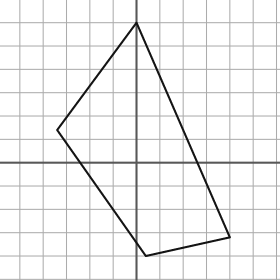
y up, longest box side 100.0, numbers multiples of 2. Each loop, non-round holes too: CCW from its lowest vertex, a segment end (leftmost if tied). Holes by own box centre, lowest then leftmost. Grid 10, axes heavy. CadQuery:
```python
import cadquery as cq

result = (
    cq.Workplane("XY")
    .moveTo(4.0, -40.0)
    .lineTo(40.0, -32.0)
    .lineTo(0.0, 60.0)
    .lineTo(-34.0, 14.0)
    .close()
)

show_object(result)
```